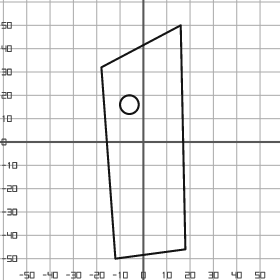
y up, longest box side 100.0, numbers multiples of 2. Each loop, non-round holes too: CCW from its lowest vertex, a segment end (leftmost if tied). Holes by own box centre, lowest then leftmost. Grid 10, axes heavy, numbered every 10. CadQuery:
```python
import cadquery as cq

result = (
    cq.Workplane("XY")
    .moveTo(-12.0, -50.0)
    .lineTo(18.0, -46.0)
    .lineTo(16.0, 50.0)
    .lineTo(-18.0, 32.0)
    .close()
    .moveTo(-6.0, 16.0)
    .circle(4.0)
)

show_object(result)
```